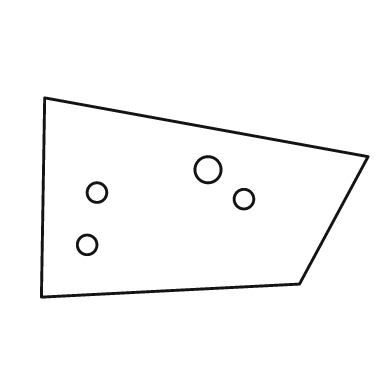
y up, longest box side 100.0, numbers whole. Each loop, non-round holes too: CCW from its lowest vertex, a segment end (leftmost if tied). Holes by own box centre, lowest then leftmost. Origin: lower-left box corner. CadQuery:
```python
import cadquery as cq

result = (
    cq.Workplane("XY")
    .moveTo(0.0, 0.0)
    .lineTo(79.0, 4.0)
    .lineTo(100.0, 43.0)
    .lineTo(1.0, 61.0)
    .close()
    .moveTo(14.0, 16.0)
    .circle(3.0)
    .moveTo(62.0, 30.0)
    .circle(3.0)
    .moveTo(17.0, 32.0)
    .circle(3.0)
    .moveTo(51.0, 39.0)
    .circle(4.0)
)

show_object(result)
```